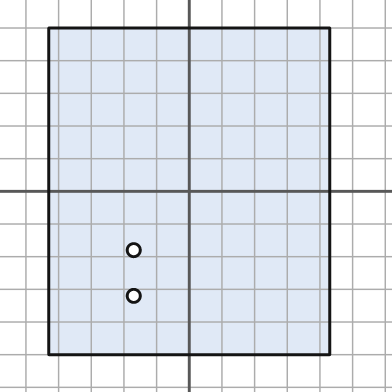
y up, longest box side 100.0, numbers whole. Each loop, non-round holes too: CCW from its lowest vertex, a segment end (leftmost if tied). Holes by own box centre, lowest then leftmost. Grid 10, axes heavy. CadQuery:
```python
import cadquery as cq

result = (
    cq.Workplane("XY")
    .moveTo(-43.0, -50.0)
    .lineTo(43.0, -50.0)
    .lineTo(43.0, 50.0)
    .lineTo(-43.0, 50.0)
    .close()
    .moveTo(-17.0, -32.0)
    .circle(2.0)
    .moveTo(-17.0, -18.0)
    .circle(2.0)
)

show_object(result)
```